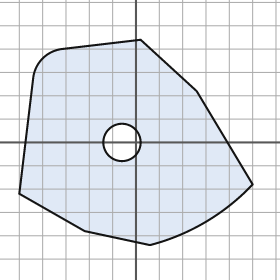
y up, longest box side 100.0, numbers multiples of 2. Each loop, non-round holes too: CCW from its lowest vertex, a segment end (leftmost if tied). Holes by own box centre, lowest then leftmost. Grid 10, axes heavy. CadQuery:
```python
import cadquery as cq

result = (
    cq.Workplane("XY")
    .moveTo(6.0, -44.0)
    .threePointArc((30.0, -34.0), (50.0, -18.0))
    .lineTo(26.0, 22.0)
    .lineTo(2.0, 44.0)
    .lineTo(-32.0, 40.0)
    .threePointArc((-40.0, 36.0), (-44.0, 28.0))
    .lineTo(-50.0, -22.0)
    .lineTo(-22.0, -38.0)
    .close()
    .moveTo(-6.0, 0.0)
    .circle(8.0)
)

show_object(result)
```